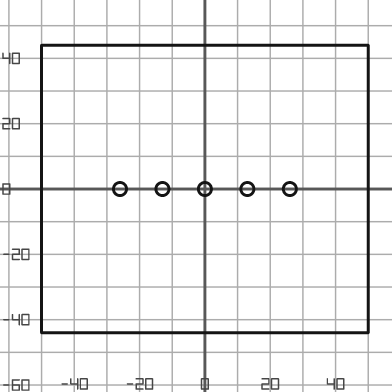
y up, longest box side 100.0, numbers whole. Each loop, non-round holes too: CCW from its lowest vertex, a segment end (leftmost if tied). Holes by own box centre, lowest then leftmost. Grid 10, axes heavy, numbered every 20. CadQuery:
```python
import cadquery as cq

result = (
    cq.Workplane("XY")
    .moveTo(-50.0, -44.0)
    .lineTo(50.0, -44.0)
    .lineTo(50.0, 44.0)
    .lineTo(-50.0, 44.0)
    .close()
    .moveTo(-26.0, 0.0)
    .circle(2.0)
    .moveTo(-13.0, 0.0)
    .circle(2.0)
    .moveTo(0.0, 0.0)
    .circle(2.0)
    .moveTo(13.0, 0.0)
    .circle(2.0)
    .moveTo(26.0, 0.0)
    .circle(2.0)
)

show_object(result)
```